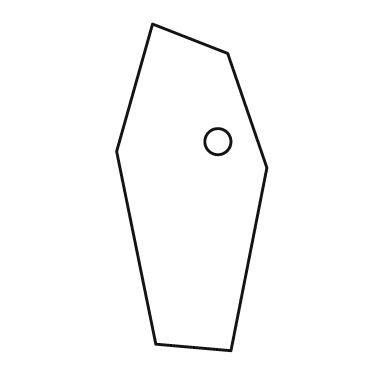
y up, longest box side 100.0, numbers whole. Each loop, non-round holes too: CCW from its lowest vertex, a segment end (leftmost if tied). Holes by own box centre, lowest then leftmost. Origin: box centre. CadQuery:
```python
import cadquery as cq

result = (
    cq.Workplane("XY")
    .moveTo(12.0, -50.0)
    .lineTo(23.0, 6.0)
    .lineTo(11.0, 41.0)
    .lineTo(-12.0, 50.0)
    .lineTo(-23.0, 11.0)
    .lineTo(-11.0, -48.0)
    .close()
    .moveTo(8.0, 14.0)
    .circle(4.0)
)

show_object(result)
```